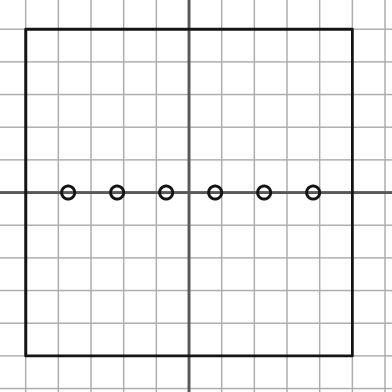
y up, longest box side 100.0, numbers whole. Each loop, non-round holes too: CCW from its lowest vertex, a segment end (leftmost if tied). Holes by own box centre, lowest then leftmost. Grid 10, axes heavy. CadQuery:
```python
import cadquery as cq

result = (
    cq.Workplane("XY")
    .moveTo(-50.0, -50.0)
    .lineTo(50.0, -50.0)
    .lineTo(50.0, 50.0)
    .lineTo(-50.0, 50.0)
    .close()
    .moveTo(-37.0, 0.0)
    .circle(2.0)
    .moveTo(-22.0, 0.0)
    .circle(2.0)
    .moveTo(-7.0, 0.0)
    .circle(2.0)
    .moveTo(8.0, 0.0)
    .circle(2.0)
    .moveTo(23.0, 0.0)
    .circle(2.0)
    .moveTo(38.0, 0.0)
    .circle(2.0)
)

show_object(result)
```